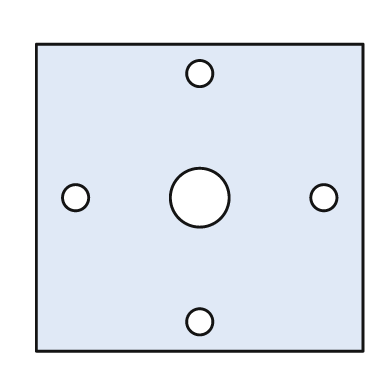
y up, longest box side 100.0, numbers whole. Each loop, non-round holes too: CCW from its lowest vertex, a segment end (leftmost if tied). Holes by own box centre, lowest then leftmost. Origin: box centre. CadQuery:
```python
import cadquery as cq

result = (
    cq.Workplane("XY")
    .moveTo(-50.0, -47.0)
    .lineTo(50.0, -47.0)
    .lineTo(50.0, 47.0)
    .lineTo(-50.0, 47.0)
    .close()
    .moveTo(0.0, -38.0)
    .circle(4.0)
    .moveTo(-38.0, 0.0)
    .circle(4.0)
    .moveTo(0.0, 0.0)
    .circle(9.0)
    .moveTo(38.0, 0.0)
    .circle(4.0)
    .moveTo(0.0, 38.0)
    .circle(4.0)
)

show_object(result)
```